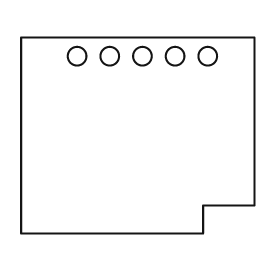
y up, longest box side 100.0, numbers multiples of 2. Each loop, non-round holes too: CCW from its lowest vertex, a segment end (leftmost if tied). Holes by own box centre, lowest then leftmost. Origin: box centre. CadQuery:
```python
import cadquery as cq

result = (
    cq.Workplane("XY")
    .moveTo(-50.0, -42.0)
    .lineTo(28.0, -42.0)
    .lineTo(28.0, -30.0)
    .lineTo(50.0, -30.0)
    .lineTo(50.0, 42.0)
    .lineTo(-50.0, 42.0)
    .close()
    .moveTo(-26.0, 34.0)
    .circle(4.0)
    .moveTo(-12.0, 34.0)
    .circle(4.0)
    .moveTo(2.0, 34.0)
    .circle(4.0)
    .moveTo(16.0, 34.0)
    .circle(4.0)
    .moveTo(30.0, 34.0)
    .circle(4.0)
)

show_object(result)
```